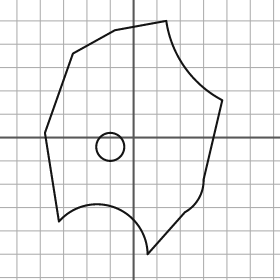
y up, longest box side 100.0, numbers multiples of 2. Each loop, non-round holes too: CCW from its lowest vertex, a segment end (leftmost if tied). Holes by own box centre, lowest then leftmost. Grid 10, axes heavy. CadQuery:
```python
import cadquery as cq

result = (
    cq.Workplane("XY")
    .moveTo(6.0, -50.0)
    .lineTo(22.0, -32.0)
    .threePointArc((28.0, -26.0), (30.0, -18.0))
    .lineTo(38.0, 16.0)
    .threePointArc((22.0, 30.0), (14.0, 50.0))
    .lineTo(-8.0, 46.0)
    .lineTo(-26.0, 36.0)
    .lineTo(-38.0, 2.0)
    .lineTo(-32.0, -36.0)
    .threePointArc((-8.0, -30.0), (6.0, -50.0))
    .close()
    .moveTo(-10.0, -4.0)
    .circle(6.0)
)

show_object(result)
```